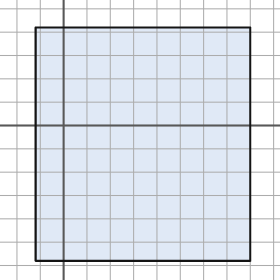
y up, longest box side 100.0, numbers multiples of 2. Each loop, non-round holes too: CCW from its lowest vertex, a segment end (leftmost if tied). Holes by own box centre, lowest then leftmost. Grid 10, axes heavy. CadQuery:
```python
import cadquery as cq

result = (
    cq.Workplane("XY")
    .moveTo(-12.0, -58.0)
    .lineTo(80.0, -58.0)
    .lineTo(80.0, 42.0)
    .lineTo(-12.0, 42.0)
    .close()
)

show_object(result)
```